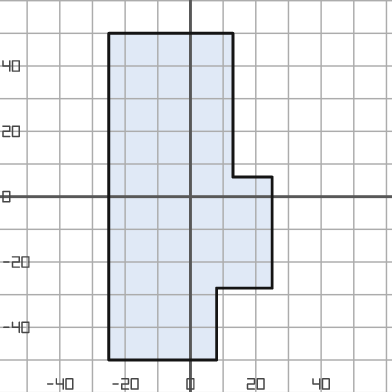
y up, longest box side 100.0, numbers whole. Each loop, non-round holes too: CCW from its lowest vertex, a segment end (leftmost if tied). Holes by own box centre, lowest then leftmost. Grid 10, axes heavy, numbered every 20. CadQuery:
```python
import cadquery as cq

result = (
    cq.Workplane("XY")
    .moveTo(-25.0, -50.0)
    .lineTo(8.0, -50.0)
    .lineTo(8.0, -28.0)
    .lineTo(25.0, -28.0)
    .lineTo(25.0, 6.0)
    .lineTo(13.0, 6.0)
    .lineTo(13.0, 50.0)
    .lineTo(-25.0, 50.0)
    .close()
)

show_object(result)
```